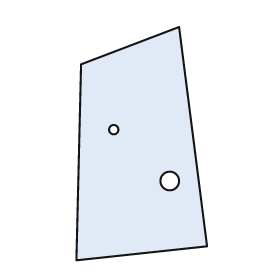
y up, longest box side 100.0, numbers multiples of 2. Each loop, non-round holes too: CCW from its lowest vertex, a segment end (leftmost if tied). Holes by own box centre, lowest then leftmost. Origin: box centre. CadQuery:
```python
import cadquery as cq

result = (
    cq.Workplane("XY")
    .moveTo(-28.0, -50.0)
    .lineTo(28.0, -44.0)
    .lineTo(16.0, 50.0)
    .lineTo(-26.0, 34.0)
    .close()
    .moveTo(12.0, -16.0)
    .circle(4.0)
    .moveTo(-12.0, 6.0)
    .circle(2.0)
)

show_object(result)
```